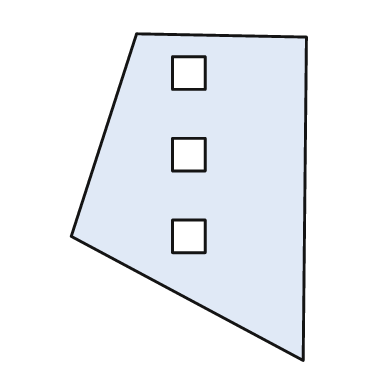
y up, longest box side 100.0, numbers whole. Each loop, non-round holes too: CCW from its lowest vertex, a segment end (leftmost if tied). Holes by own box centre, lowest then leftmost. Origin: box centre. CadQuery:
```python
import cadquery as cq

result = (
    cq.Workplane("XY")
    .moveTo(35.0, -50.0)
    .lineTo(36.0, 49.0)
    .lineTo(-16.0, 50.0)
    .lineTo(-36.0, -12.0)
    .close()
    .moveTo(-5.0, -17.0)
    .lineTo(5.0, -17.0)
    .lineTo(5.0, -7.0)
    .lineTo(-5.0, -7.0)
    .close()
    .moveTo(-5.0, 8.0)
    .lineTo(5.0, 8.0)
    .lineTo(5.0, 18.0)
    .lineTo(-5.0, 18.0)
    .close()
    .moveTo(-5.0, 33.0)
    .lineTo(5.0, 33.0)
    .lineTo(5.0, 43.0)
    .lineTo(-5.0, 43.0)
    .close()
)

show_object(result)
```